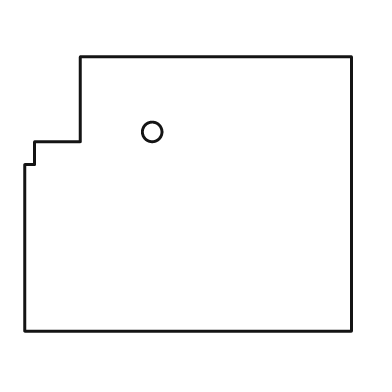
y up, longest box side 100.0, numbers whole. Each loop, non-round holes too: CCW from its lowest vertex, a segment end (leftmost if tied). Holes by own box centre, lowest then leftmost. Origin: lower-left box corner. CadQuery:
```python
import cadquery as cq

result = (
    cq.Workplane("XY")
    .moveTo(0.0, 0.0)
    .lineTo(100.0, 0.0)
    .lineTo(100.0, 84.0)
    .lineTo(17.0, 84.0)
    .lineTo(17.0, 58.0)
    .lineTo(3.0, 58.0)
    .lineTo(3.0, 51.0)
    .lineTo(0.0, 51.0)
    .close()
    .moveTo(39.0, 61.0)
    .circle(3.0)
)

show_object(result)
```